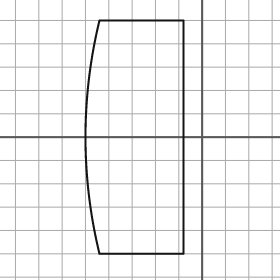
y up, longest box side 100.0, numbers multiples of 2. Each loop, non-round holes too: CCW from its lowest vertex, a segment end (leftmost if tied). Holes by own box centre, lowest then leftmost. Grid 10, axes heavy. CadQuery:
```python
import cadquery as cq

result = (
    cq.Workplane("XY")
    .moveTo(-44.0, -50.0)
    .lineTo(-8.0, -50.0)
    .lineTo(-8.0, 50.0)
    .lineTo(-44.0, 50.0)
    .threePointArc((-50.0, 0.0), (-44.0, -50.0))
    .close()
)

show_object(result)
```